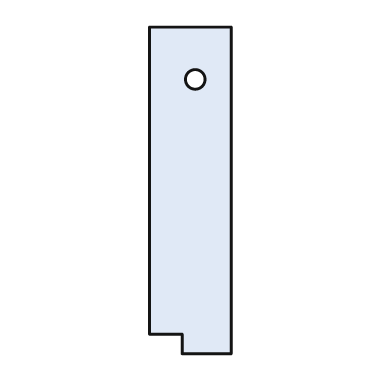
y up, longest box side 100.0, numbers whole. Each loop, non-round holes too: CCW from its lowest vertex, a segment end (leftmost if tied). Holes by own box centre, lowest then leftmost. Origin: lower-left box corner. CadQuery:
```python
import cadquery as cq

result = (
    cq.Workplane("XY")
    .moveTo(10.0, 0.0)
    .lineTo(25.0, 0.0)
    .lineTo(25.0, 100.0)
    .lineTo(0.0, 100.0)
    .lineTo(0.0, 6.0)
    .lineTo(10.0, 6.0)
    .close()
    .moveTo(14.0, 84.0)
    .circle(3.0)
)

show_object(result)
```